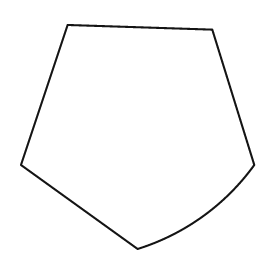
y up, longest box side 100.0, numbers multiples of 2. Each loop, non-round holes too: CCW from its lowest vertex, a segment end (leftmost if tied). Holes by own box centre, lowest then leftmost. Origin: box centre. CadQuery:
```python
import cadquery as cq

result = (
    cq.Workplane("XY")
    .moveTo(0.0, -48.0)
    .threePointArc((28.0, -34.0), (50.0, -12.0))
    .lineTo(32.0, 46.0)
    .lineTo(-30.0, 48.0)
    .lineTo(-50.0, -12.0)
    .close()
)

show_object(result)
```